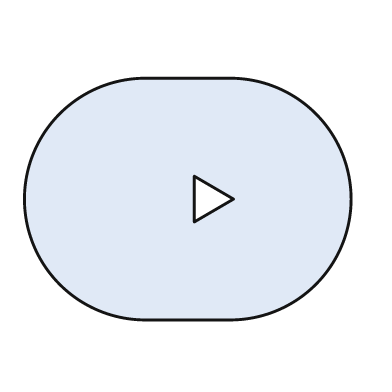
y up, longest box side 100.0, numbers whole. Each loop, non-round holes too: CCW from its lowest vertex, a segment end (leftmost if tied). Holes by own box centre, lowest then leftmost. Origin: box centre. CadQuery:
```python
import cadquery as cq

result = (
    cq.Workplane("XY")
    .moveTo(-13.0, -37.0)
    .lineTo(13.0, -37.0)
    .threePointArc((50.0, 0.0), (13.0, 37.0))
    .lineTo(-13.0, 37.0)
    .threePointArc((-50.0, 0.0), (-13.0, -37.0))
    .close()
    .moveTo(2.0, -7.0)
    .lineTo(14.0, 0.0)
    .lineTo(2.0, 7.0)
    .close()
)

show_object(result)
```